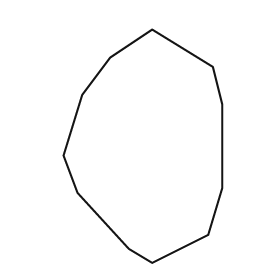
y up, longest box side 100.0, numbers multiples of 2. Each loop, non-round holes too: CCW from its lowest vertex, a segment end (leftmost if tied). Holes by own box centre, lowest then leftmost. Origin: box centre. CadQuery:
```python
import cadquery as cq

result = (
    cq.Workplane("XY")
    .moveTo(4.0, -50.0)
    .lineTo(28.0, -38.0)
    .lineTo(34.0, -18.0)
    .lineTo(34.0, 18.0)
    .lineTo(30.0, 34.0)
    .lineTo(4.0, 50.0)
    .lineTo(-14.0, 38.0)
    .lineTo(-26.0, 22.0)
    .lineTo(-34.0, -4.0)
    .lineTo(-28.0, -20.0)
    .lineTo(-6.0, -44.0)
    .close()
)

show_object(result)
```